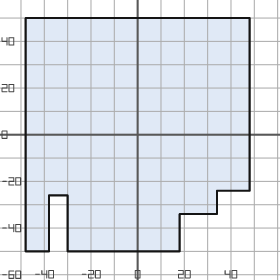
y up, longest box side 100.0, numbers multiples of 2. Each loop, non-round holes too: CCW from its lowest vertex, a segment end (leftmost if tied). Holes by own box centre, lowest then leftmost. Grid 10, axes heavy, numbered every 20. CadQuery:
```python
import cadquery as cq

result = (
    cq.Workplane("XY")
    .moveTo(-48.0, -50.0)
    .lineTo(-38.0, -50.0)
    .lineTo(-38.0, -26.0)
    .lineTo(-30.0, -26.0)
    .lineTo(-30.0, -50.0)
    .lineTo(18.0, -50.0)
    .lineTo(18.0, -34.0)
    .lineTo(34.0, -34.0)
    .lineTo(34.0, -24.0)
    .lineTo(48.0, -24.0)
    .lineTo(48.0, 50.0)
    .lineTo(-48.0, 50.0)
    .close()
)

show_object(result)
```